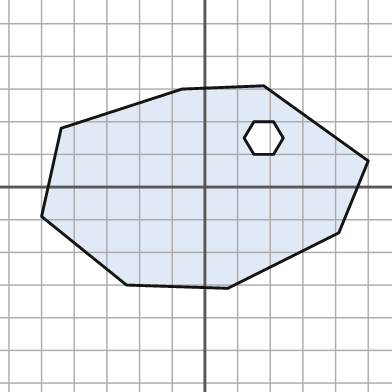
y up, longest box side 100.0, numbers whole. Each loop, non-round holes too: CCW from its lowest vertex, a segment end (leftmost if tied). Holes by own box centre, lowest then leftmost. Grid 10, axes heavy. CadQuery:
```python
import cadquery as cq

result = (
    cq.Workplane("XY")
    .moveTo(7.0, -31.0)
    .lineTo(41.0, -14.0)
    .lineTo(50.0, 8.0)
    .lineTo(18.0, 31.0)
    .lineTo(-7.0, 30.0)
    .lineTo(-44.0, 18.0)
    .lineTo(-50.0, -9.0)
    .lineTo(-24.0, -30.0)
    .close()
    .moveTo(15.0, 10.0)
    .lineTo(21.0, 10.0)
    .lineTo(24.0, 15.0)
    .lineTo(21.0, 20.0)
    .lineTo(15.0, 20.0)
    .lineTo(12.0, 15.0)
    .close()
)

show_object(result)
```